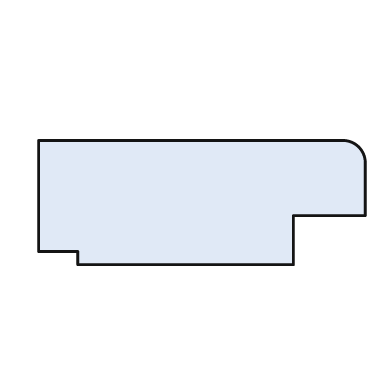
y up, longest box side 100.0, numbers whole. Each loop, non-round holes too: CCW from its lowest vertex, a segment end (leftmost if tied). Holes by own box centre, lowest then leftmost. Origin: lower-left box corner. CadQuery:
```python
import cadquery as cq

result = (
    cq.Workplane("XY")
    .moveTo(12.0, 0.0)
    .lineTo(78.0, 0.0)
    .lineTo(78.0, 15.0)
    .lineTo(100.0, 15.0)
    .lineTo(100.0, 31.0)
    .threePointArc((98.0, 36.0), (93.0, 38.0))
    .lineTo(0.0, 38.0)
    .lineTo(0.0, 4.0)
    .lineTo(12.0, 4.0)
    .close()
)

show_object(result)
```